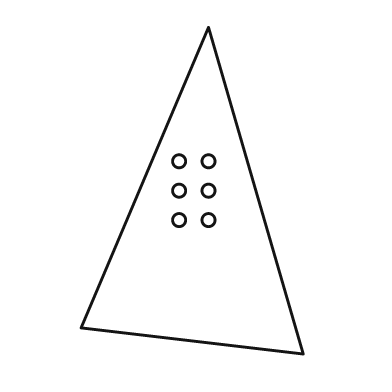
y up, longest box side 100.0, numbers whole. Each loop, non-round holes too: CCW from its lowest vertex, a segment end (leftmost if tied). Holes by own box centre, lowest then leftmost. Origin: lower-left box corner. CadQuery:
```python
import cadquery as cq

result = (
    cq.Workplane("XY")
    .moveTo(68.0, 0.0)
    .lineTo(39.0, 100.0)
    .lineTo(0.0, 8.0)
    .close()
    .moveTo(30.0, 41.0)
    .circle(2.0)
    .moveTo(39.0, 41.0)
    .circle(2.0)
    .moveTo(30.0, 50.0)
    .circle(2.0)
    .moveTo(39.0, 50.0)
    .circle(2.0)
    .moveTo(30.0, 59.0)
    .circle(2.0)
    .moveTo(39.0, 59.0)
    .circle(2.0)
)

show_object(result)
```